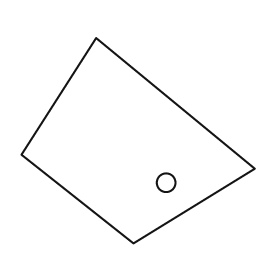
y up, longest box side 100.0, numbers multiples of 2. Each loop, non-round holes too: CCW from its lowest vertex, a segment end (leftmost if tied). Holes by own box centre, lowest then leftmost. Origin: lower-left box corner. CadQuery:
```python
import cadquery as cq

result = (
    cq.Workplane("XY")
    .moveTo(48.0, 0.0)
    .lineTo(100.0, 32.0)
    .lineTo(32.0, 88.0)
    .lineTo(0.0, 38.0)
    .close()
    .moveTo(62.0, 26.0)
    .circle(4.0)
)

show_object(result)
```